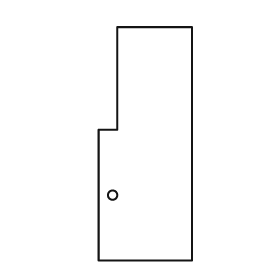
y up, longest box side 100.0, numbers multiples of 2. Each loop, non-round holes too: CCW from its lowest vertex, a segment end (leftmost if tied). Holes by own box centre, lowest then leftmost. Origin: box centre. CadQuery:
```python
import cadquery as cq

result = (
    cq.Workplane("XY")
    .moveTo(-20.0, -50.0)
    .lineTo(20.0, -50.0)
    .lineTo(20.0, 50.0)
    .lineTo(-12.0, 50.0)
    .lineTo(-12.0, 6.0)
    .lineTo(-20.0, 6.0)
    .close()
    .moveTo(-14.0, -22.0)
    .circle(2.0)
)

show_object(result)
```